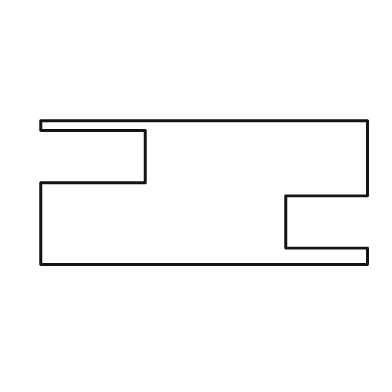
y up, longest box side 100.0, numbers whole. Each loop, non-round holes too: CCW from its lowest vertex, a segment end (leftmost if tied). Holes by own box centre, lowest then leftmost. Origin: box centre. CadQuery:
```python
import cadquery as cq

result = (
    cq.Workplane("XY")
    .moveTo(-50.0, -22.0)
    .lineTo(50.0, -22.0)
    .lineTo(50.0, -17.0)
    .lineTo(25.0, -17.0)
    .lineTo(25.0, -1.0)
    .lineTo(50.0, -1.0)
    .lineTo(50.0, 22.0)
    .lineTo(-50.0, 22.0)
    .lineTo(-50.0, 19.0)
    .lineTo(-18.0, 19.0)
    .lineTo(-18.0, 3.0)
    .lineTo(-50.0, 3.0)
    .close()
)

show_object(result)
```